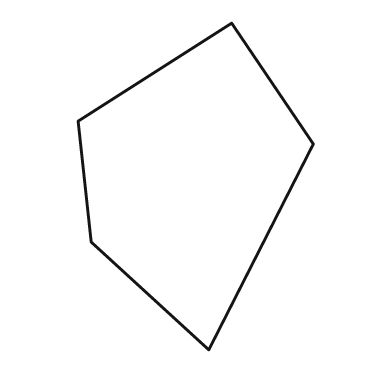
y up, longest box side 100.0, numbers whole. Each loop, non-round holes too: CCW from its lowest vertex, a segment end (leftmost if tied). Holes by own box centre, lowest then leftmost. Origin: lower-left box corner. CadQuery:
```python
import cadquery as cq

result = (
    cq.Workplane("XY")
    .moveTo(40.0, 0.0)
    .lineTo(72.0, 63.0)
    .lineTo(47.0, 100.0)
    .lineTo(0.0, 70.0)
    .lineTo(4.0, 33.0)
    .close()
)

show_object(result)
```